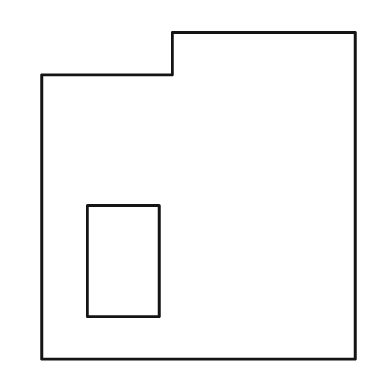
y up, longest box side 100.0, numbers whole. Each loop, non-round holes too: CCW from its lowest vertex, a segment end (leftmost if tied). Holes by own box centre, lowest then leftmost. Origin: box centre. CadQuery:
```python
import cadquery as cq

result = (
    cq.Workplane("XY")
    .moveTo(-48.0, -50.0)
    .lineTo(48.0, -50.0)
    .lineTo(48.0, 50.0)
    .lineTo(-8.0, 50.0)
    .lineTo(-8.0, 37.0)
    .lineTo(-48.0, 37.0)
    .close()
    .moveTo(-34.0, -37.0)
    .lineTo(-12.0, -37.0)
    .lineTo(-12.0, -3.0)
    .lineTo(-34.0, -3.0)
    .close()
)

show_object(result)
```